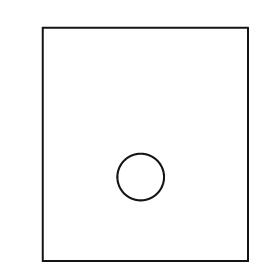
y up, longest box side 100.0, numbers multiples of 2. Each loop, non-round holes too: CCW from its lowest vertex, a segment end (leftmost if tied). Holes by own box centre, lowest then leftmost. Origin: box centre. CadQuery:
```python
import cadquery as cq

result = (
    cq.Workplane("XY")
    .moveTo(-44.0, -50.0)
    .lineTo(44.0, -50.0)
    .lineTo(44.0, 50.0)
    .lineTo(-44.0, 50.0)
    .close()
    .moveTo(-2.0, -14.0)
    .circle(10.0)
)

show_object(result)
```